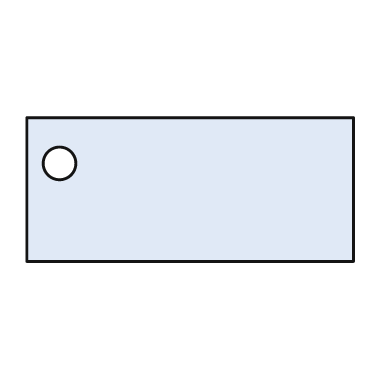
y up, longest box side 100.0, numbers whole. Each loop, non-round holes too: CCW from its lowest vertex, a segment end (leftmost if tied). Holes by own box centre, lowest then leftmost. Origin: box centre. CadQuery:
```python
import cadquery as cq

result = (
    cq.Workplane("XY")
    .moveTo(-50.0, -22.0)
    .lineTo(50.0, -22.0)
    .lineTo(50.0, 22.0)
    .lineTo(-50.0, 22.0)
    .close()
    .moveTo(-40.0, 8.0)
    .circle(5.0)
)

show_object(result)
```